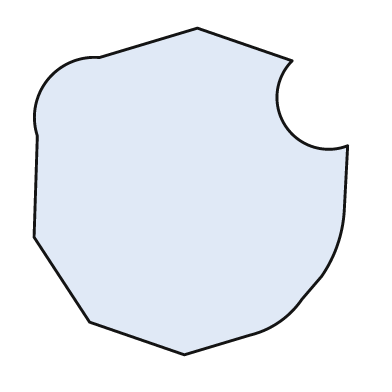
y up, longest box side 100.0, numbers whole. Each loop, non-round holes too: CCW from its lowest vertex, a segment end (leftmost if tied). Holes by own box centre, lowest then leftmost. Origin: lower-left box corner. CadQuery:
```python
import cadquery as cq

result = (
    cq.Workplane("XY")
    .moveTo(46.0, 0.0)
    .lineTo(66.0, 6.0)
    .threePointArc((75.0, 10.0), (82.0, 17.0))
    .lineTo(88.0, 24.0)
    .threePointArc((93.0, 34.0), (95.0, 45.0))
    .lineTo(96.0, 64.0)
    .threePointArc((77.0, 70.0), (79.0, 90.0))
    .lineTo(50.0, 100.0)
    .lineTo(20.0, 91.0)
    .threePointArc((4.0, 84.0), (1.0, 67.0))
    .lineTo(0.0, 36.0)
    .lineTo(17.0, 10.0)
    .close()
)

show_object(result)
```